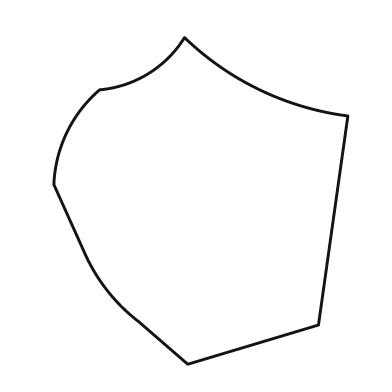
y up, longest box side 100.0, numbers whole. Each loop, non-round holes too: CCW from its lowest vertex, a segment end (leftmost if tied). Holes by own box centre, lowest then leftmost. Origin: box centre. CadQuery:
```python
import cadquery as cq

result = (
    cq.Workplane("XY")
    .moveTo(-4.0, -50.0)
    .lineTo(36.0, -38.0)
    .lineTo(45.0, 26.0)
    .threePointArc((18.0, 34.0), (-5.0, 50.0))
    .threePointArc((-16.0, 39.0), (-31.0, 34.0))
    .threePointArc((-41.0, 21.0), (-45.0, 5.0))
    .lineTo(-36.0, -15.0)
    .threePointArc((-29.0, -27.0), (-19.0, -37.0))
    .close()
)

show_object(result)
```